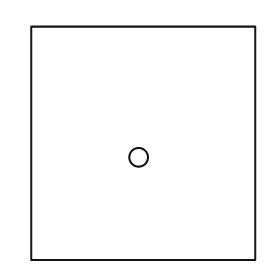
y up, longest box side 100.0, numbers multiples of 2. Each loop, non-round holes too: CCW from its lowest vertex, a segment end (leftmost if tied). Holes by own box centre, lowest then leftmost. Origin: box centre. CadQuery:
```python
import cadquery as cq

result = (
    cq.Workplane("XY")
    .moveTo(-48.0, -50.0)
    .lineTo(48.0, -50.0)
    .lineTo(48.0, 50.0)
    .lineTo(-48.0, 50.0)
    .close()
    .moveTo(-2.0, -6.0)
    .circle(4.0)
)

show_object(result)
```